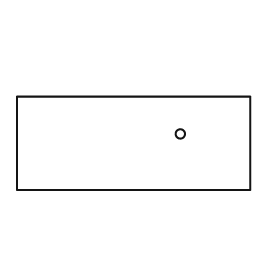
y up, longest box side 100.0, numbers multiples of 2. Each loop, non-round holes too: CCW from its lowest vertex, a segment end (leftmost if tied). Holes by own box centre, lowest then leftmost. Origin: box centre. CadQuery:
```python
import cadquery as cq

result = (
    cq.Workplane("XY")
    .moveTo(-50.0, -20.0)
    .lineTo(50.0, -20.0)
    .lineTo(50.0, 20.0)
    .lineTo(-50.0, 20.0)
    .close()
    .moveTo(20.0, 4.0)
    .circle(2.0)
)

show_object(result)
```